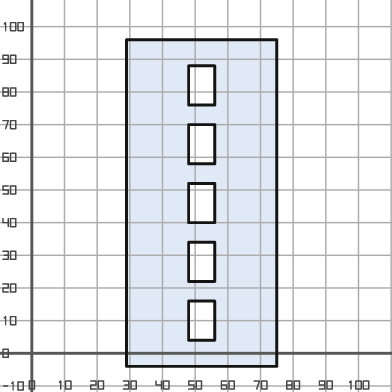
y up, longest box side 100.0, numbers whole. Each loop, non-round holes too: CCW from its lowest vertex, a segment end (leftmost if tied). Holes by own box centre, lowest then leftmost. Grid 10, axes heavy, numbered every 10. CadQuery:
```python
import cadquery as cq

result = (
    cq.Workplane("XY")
    .moveTo(29.0, -4.0)
    .lineTo(75.0, -4.0)
    .lineTo(75.0, 96.0)
    .lineTo(29.0, 96.0)
    .close()
    .moveTo(48.0, 4.0)
    .lineTo(56.0, 4.0)
    .lineTo(56.0, 16.0)
    .lineTo(48.0, 16.0)
    .close()
    .moveTo(48.0, 22.0)
    .lineTo(56.0, 22.0)
    .lineTo(56.0, 34.0)
    .lineTo(48.0, 34.0)
    .close()
    .moveTo(48.0, 40.0)
    .lineTo(56.0, 40.0)
    .lineTo(56.0, 52.0)
    .lineTo(48.0, 52.0)
    .close()
    .moveTo(48.0, 58.0)
    .lineTo(56.0, 58.0)
    .lineTo(56.0, 70.0)
    .lineTo(48.0, 70.0)
    .close()
    .moveTo(48.0, 76.0)
    .lineTo(56.0, 76.0)
    .lineTo(56.0, 88.0)
    .lineTo(48.0, 88.0)
    .close()
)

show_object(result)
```